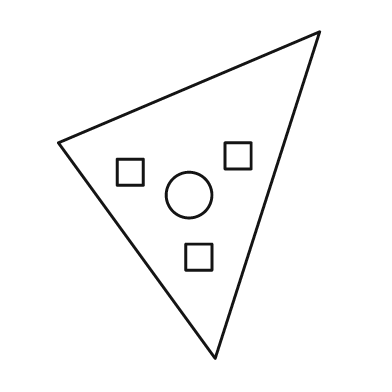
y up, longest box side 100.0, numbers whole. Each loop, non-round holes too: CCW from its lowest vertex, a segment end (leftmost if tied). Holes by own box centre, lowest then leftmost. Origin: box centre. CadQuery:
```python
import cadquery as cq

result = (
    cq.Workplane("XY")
    .moveTo(8.0, -50.0)
    .lineTo(40.0, 50.0)
    .lineTo(-40.0, 16.0)
    .close()
    .moveTo(-1.0, -23.0)
    .lineTo(7.0, -23.0)
    .lineTo(7.0, -15.0)
    .lineTo(-1.0, -15.0)
    .close()
    .moveTo(0.0, 0.0)
    .circle(7.0)
    .moveTo(-22.0, 3.0)
    .lineTo(-14.0, 3.0)
    .lineTo(-14.0, 11.0)
    .lineTo(-22.0, 11.0)
    .close()
    .moveTo(11.0, 8.0)
    .lineTo(19.0, 8.0)
    .lineTo(19.0, 16.0)
    .lineTo(11.0, 16.0)
    .close()
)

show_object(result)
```